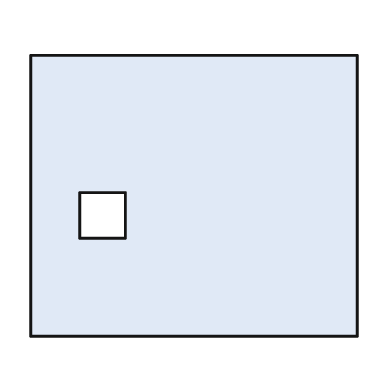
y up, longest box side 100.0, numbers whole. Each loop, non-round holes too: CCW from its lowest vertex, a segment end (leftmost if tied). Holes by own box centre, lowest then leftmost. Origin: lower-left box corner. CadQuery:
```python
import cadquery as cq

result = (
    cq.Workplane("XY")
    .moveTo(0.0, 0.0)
    .lineTo(100.0, 0.0)
    .lineTo(100.0, 86.0)
    .lineTo(0.0, 86.0)
    .close()
    .moveTo(15.0, 30.0)
    .lineTo(29.0, 30.0)
    .lineTo(29.0, 44.0)
    .lineTo(15.0, 44.0)
    .close()
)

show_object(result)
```